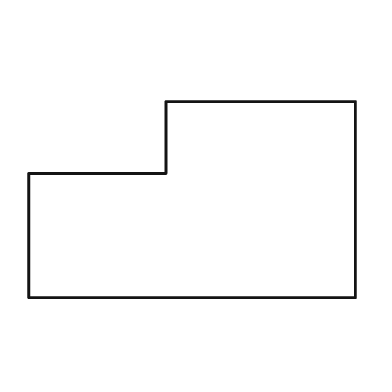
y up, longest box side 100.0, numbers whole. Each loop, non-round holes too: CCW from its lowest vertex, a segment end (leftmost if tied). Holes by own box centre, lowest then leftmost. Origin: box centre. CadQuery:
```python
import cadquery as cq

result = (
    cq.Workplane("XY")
    .moveTo(-50.0, -30.0)
    .lineTo(50.0, -30.0)
    .lineTo(50.0, 30.0)
    .lineTo(-8.0, 30.0)
    .lineTo(-8.0, 8.0)
    .lineTo(-50.0, 8.0)
    .close()
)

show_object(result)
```